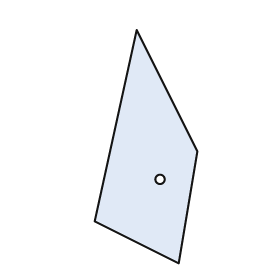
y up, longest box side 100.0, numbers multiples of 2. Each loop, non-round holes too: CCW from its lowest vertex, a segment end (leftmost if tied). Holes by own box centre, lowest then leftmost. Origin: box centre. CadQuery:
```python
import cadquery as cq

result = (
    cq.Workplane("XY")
    .moveTo(14.0, -50.0)
    .lineTo(22.0, -2.0)
    .lineTo(-4.0, 50.0)
    .lineTo(-22.0, -32.0)
    .close()
    .moveTo(6.0, -14.0)
    .circle(2.0)
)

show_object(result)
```